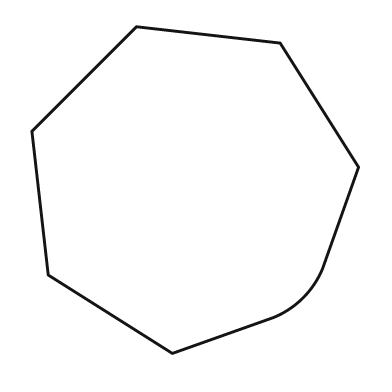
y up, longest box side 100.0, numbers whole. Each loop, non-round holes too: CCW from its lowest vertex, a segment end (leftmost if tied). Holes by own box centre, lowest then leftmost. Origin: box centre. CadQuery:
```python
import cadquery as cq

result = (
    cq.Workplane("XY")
    .moveTo(-7.0, -50.0)
    .lineTo(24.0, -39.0)
    .threePointArc((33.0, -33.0), (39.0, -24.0))
    .lineTo(50.0, 7.0)
    .lineTo(26.0, 45.0)
    .lineTo(-18.0, 50.0)
    .lineTo(-50.0, 18.0)
    .lineTo(-45.0, -26.0)
    .close()
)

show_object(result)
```